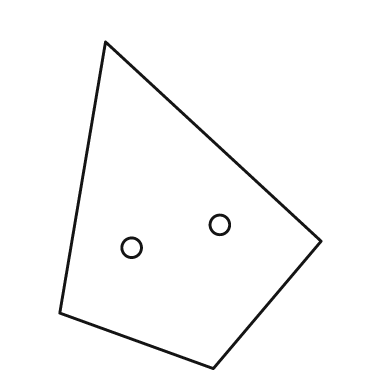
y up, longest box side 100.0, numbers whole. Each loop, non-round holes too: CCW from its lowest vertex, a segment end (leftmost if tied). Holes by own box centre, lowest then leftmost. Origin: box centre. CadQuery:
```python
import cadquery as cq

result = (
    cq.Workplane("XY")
    .moveTo(7.0, -50.0)
    .lineTo(40.0, -11.0)
    .lineTo(-26.0, 50.0)
    .lineTo(-40.0, -33.0)
    .close()
    .moveTo(-18.0, -13.0)
    .circle(3.0)
    .moveTo(9.0, -6.0)
    .circle(3.0)
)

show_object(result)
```